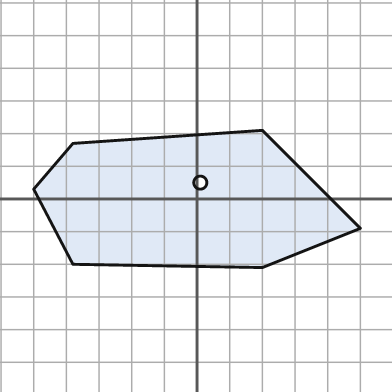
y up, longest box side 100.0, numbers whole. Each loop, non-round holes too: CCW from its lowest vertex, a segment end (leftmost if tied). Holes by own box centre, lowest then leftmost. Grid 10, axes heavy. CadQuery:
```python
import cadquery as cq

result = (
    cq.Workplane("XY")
    .moveTo(20.0, -21.0)
    .lineTo(50.0, -9.0)
    .lineTo(20.0, 21.0)
    .lineTo(-38.0, 17.0)
    .lineTo(-50.0, 3.0)
    .lineTo(-38.0, -20.0)
    .close()
    .moveTo(1.0, 5.0)
    .circle(2.0)
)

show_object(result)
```